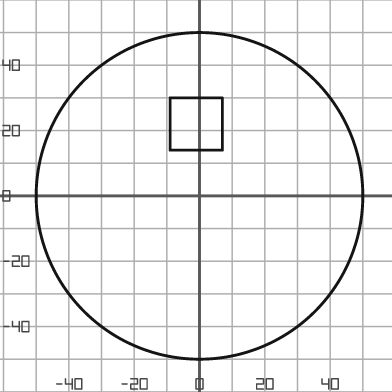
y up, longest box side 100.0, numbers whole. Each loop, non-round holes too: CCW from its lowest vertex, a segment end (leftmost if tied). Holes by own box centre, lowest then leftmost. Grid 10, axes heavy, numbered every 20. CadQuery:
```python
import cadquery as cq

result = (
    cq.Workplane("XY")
    .moveTo(0.0, 0.0)
    .circle(50.0)
    .moveTo(-9.0, 14.0)
    .lineTo(7.0, 14.0)
    .lineTo(7.0, 30.0)
    .lineTo(-9.0, 30.0)
    .close()
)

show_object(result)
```